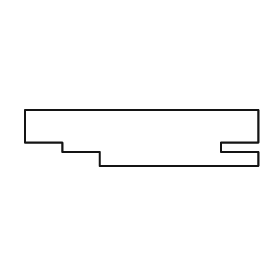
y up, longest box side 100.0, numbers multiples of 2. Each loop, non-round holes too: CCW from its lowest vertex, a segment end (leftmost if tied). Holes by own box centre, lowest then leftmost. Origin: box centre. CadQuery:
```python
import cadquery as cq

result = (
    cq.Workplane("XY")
    .moveTo(-18.0, -12.0)
    .lineTo(50.0, -12.0)
    .lineTo(50.0, -6.0)
    .lineTo(34.0, -6.0)
    .lineTo(34.0, -2.0)
    .lineTo(50.0, -2.0)
    .lineTo(50.0, 12.0)
    .lineTo(-50.0, 12.0)
    .lineTo(-50.0, -2.0)
    .lineTo(-34.0, -2.0)
    .lineTo(-34.0, -6.0)
    .lineTo(-18.0, -6.0)
    .close()
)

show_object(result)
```